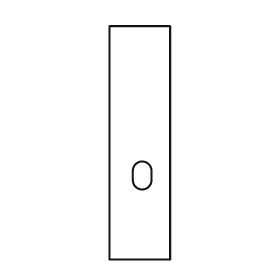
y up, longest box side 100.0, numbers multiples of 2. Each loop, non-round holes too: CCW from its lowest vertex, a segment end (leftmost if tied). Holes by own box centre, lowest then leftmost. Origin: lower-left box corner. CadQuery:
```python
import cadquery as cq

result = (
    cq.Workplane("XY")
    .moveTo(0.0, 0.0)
    .lineTo(26.0, 0.0)
    .lineTo(26.0, 100.0)
    .lineTo(0.0, 100.0)
    .close()
    .moveTo(10.0, 34.0)
    .threePointArc((14.0, 30.0), (18.0, 34.0))
    .lineTo(18.0, 38.0)
    .threePointArc((14.0, 42.0), (10.0, 38.0))
    .close()
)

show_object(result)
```